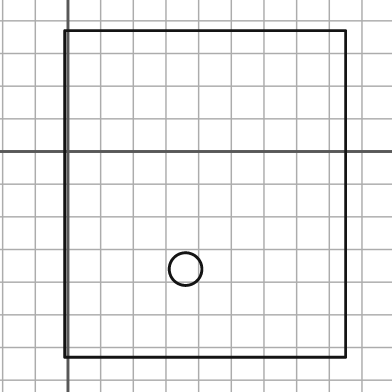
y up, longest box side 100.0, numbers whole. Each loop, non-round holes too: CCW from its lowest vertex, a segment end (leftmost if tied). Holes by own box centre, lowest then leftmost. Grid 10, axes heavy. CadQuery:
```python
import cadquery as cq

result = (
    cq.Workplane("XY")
    .moveTo(-1.0, -63.0)
    .lineTo(85.0, -63.0)
    .lineTo(85.0, 37.0)
    .lineTo(-1.0, 37.0)
    .close()
    .moveTo(36.0, -36.0)
    .circle(5.0)
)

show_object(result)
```